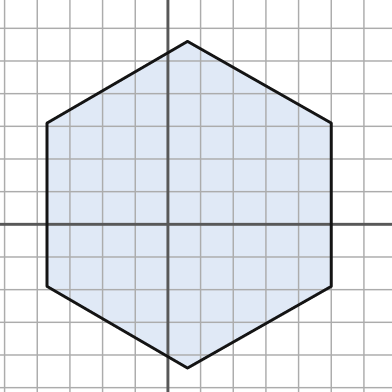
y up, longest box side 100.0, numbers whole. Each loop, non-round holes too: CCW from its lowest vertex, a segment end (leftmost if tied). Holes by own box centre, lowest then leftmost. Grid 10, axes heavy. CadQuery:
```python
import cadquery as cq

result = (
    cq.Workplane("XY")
    .moveTo(6.0, -44.0)
    .lineTo(50.0, -19.0)
    .lineTo(50.0, 31.0)
    .lineTo(6.0, 56.0)
    .lineTo(-37.0, 31.0)
    .lineTo(-37.0, -19.0)
    .close()
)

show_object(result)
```